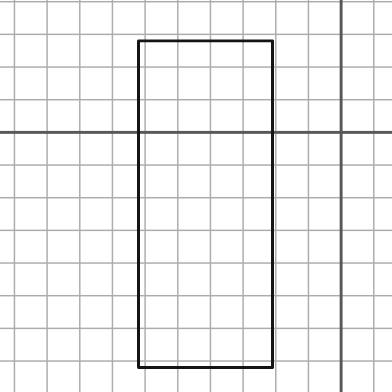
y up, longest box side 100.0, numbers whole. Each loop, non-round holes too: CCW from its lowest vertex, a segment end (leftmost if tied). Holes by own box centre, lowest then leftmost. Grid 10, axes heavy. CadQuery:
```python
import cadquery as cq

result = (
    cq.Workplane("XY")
    .moveTo(-62.0, -72.0)
    .lineTo(-21.0, -72.0)
    .lineTo(-21.0, 28.0)
    .lineTo(-62.0, 28.0)
    .close()
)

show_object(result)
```